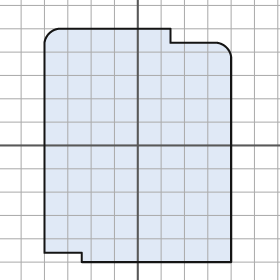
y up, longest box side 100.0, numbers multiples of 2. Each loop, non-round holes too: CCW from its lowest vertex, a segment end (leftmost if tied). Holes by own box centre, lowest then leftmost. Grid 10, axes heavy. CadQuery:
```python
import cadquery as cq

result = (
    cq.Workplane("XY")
    .moveTo(-24.0, -50.0)
    .lineTo(40.0, -50.0)
    .lineTo(40.0, 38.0)
    .threePointArc((38.0, 42.0), (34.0, 44.0))
    .lineTo(14.0, 44.0)
    .lineTo(14.0, 50.0)
    .lineTo(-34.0, 50.0)
    .threePointArc((-38.0, 48.0), (-40.0, 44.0))
    .lineTo(-40.0, -46.0)
    .lineTo(-24.0, -46.0)
    .close()
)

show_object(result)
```